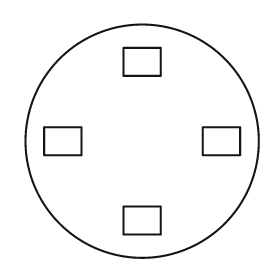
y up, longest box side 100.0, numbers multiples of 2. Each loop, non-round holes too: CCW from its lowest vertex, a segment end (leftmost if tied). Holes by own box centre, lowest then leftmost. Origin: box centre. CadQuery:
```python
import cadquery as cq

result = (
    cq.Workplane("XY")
    .moveTo(0.0, 0.0)
    .circle(50.0)
    .moveTo(-8.0, -40.0)
    .lineTo(8.0, -40.0)
    .lineTo(8.0, -28.0)
    .lineTo(-8.0, -28.0)
    .close()
    .moveTo(-42.0, -6.0)
    .lineTo(-26.0, -6.0)
    .lineTo(-26.0, 6.0)
    .lineTo(-42.0, 6.0)
    .close()
    .moveTo(26.0, -6.0)
    .lineTo(42.0, -6.0)
    .lineTo(42.0, 6.0)
    .lineTo(26.0, 6.0)
    .close()
    .moveTo(-8.0, 28.0)
    .lineTo(8.0, 28.0)
    .lineTo(8.0, 40.0)
    .lineTo(-8.0, 40.0)
    .close()
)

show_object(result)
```